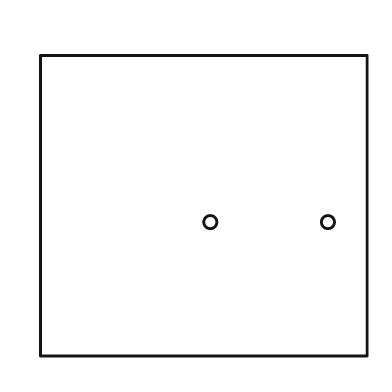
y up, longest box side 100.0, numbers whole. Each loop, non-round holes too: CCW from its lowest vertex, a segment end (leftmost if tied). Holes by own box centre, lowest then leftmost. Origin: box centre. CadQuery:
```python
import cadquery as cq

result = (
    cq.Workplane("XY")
    .moveTo(-50.0, -46.0)
    .lineTo(50.0, -46.0)
    .lineTo(50.0, 46.0)
    .lineTo(-50.0, 46.0)
    .close()
    .moveTo(2.0, -5.0)
    .circle(2.0)
    .moveTo(38.0, -5.0)
    .circle(2.0)
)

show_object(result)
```